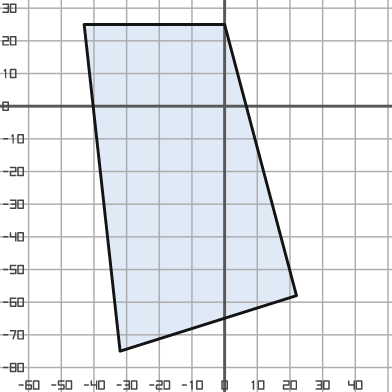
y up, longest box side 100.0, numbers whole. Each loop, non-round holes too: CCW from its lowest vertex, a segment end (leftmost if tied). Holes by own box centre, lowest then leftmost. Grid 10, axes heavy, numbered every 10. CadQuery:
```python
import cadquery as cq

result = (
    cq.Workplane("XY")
    .moveTo(-32.0, -75.0)
    .lineTo(22.0, -58.0)
    .lineTo(0.0, 25.0)
    .lineTo(-43.0, 25.0)
    .close()
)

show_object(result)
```